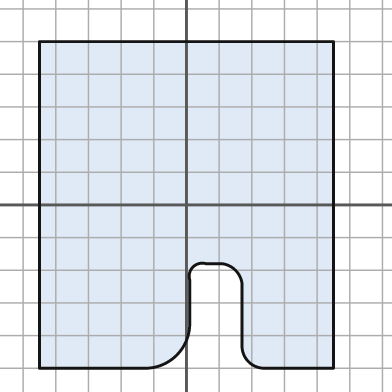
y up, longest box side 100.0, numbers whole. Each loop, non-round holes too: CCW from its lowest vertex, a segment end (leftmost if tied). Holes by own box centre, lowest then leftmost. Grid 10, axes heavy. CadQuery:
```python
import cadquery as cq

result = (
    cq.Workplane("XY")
    .moveTo(-45.0, -50.0)
    .lineTo(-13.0, -50.0)
    .threePointArc((-3.0, -46.0), (1.0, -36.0))
    .lineTo(1.0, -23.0)
    .threePointArc((2.0, -19.0), (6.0, -18.0))
    .lineTo(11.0, -18.0)
    .threePointArc((15.0, -20.0), (17.0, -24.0))
    .lineTo(17.0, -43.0)
    .threePointArc((19.0, -48.0), (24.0, -50.0))
    .lineTo(45.0, -50.0)
    .lineTo(45.0, 50.0)
    .lineTo(-45.0, 50.0)
    .close()
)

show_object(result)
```